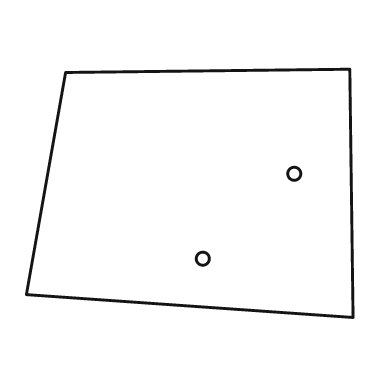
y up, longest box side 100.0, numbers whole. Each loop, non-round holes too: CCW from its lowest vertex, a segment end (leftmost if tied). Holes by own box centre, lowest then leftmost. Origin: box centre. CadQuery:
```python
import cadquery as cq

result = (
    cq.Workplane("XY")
    .moveTo(50.0, -38.0)
    .lineTo(49.0, 38.0)
    .lineTo(-38.0, 37.0)
    .lineTo(-50.0, -31.0)
    .close()
    .moveTo(4.0, -20.0)
    .circle(2.0)
    .moveTo(32.0, 6.0)
    .circle(2.0)
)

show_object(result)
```